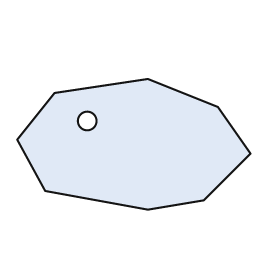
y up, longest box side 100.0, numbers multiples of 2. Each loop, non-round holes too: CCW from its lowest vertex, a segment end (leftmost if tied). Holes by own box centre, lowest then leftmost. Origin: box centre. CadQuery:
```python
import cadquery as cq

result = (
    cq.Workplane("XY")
    .moveTo(6.0, -28.0)
    .lineTo(30.0, -24.0)
    .lineTo(50.0, -4.0)
    .lineTo(36.0, 16.0)
    .lineTo(6.0, 28.0)
    .lineTo(-34.0, 22.0)
    .lineTo(-50.0, 2.0)
    .lineTo(-38.0, -20.0)
    .close()
    .moveTo(-20.0, 10.0)
    .circle(4.0)
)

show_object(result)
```